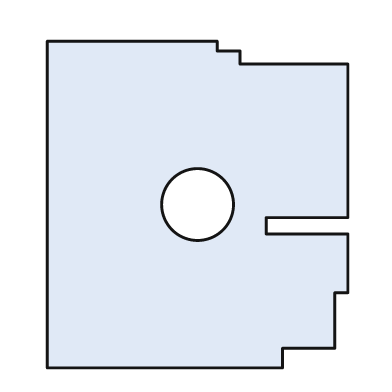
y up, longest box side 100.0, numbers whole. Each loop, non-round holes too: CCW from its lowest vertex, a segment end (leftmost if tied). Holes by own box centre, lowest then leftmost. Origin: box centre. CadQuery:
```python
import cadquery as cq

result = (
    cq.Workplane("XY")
    .moveTo(-46.0, -50.0)
    .lineTo(26.0, -50.0)
    .lineTo(26.0, -44.0)
    .lineTo(42.0, -44.0)
    .lineTo(42.0, -27.0)
    .lineTo(46.0, -27.0)
    .lineTo(46.0, -9.0)
    .lineTo(21.0, -9.0)
    .lineTo(21.0, -4.0)
    .lineTo(46.0, -4.0)
    .lineTo(46.0, 43.0)
    .lineTo(13.0, 43.0)
    .lineTo(13.0, 47.0)
    .lineTo(6.0, 47.0)
    .lineTo(6.0, 50.0)
    .lineTo(-46.0, 50.0)
    .close()
    .moveTo(0.0, 0.0)
    .circle(11.0)
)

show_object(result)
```